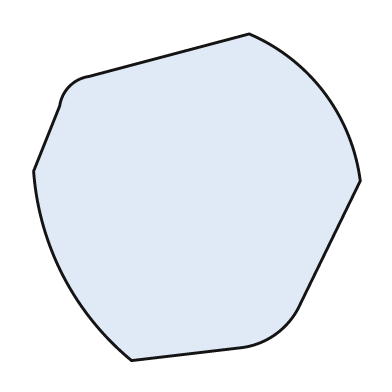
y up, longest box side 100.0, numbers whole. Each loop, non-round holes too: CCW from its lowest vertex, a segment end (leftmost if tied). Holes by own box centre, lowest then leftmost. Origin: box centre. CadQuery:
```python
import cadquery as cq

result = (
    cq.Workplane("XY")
    .moveTo(-20.0, -50.0)
    .lineTo(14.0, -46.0)
    .threePointArc((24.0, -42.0), (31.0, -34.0))
    .lineTo(50.0, 5.0)
    .threePointArc((39.0, 32.0), (16.0, 50.0))
    .lineTo(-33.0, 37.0)
    .threePointArc((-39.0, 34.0), (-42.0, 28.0))
    .lineTo(-50.0, 8.0)
    .threePointArc((-41.0, -24.0), (-20.0, -50.0))
    .close()
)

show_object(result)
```